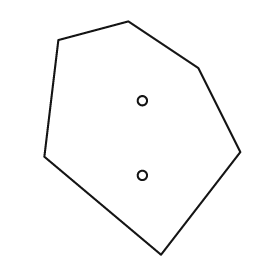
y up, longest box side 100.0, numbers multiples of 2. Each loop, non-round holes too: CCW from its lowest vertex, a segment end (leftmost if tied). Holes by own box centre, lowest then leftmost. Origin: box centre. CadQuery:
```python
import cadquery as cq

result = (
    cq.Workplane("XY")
    .moveTo(8.0, -50.0)
    .lineTo(42.0, -6.0)
    .lineTo(24.0, 30.0)
    .lineTo(-6.0, 50.0)
    .lineTo(-36.0, 42.0)
    .lineTo(-42.0, -8.0)
    .close()
    .moveTo(0.0, -16.0)
    .circle(2.0)
    .moveTo(0.0, 16.0)
    .circle(2.0)
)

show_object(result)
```